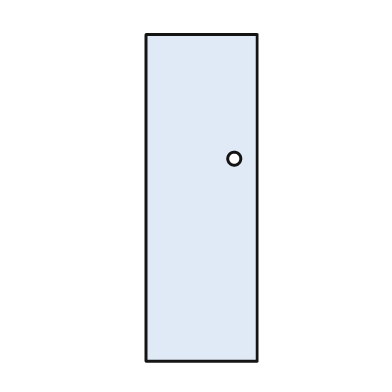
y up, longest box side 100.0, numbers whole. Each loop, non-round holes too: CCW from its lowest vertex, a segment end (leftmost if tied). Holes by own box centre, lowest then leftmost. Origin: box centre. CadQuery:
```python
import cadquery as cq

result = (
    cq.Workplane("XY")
    .moveTo(-17.0, -50.0)
    .lineTo(17.0, -50.0)
    .lineTo(17.0, 50.0)
    .lineTo(-17.0, 50.0)
    .close()
    .moveTo(10.0, 12.0)
    .circle(2.0)
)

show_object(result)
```